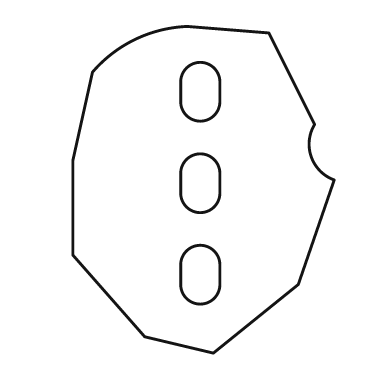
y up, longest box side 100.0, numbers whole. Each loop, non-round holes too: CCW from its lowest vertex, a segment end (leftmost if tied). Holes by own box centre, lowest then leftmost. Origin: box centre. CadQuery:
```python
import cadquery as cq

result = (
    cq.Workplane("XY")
    .moveTo(3.0, -50.0)
    .lineTo(29.0, -29.0)
    .lineTo(40.0, 3.0)
    .threePointArc((33.0, 10.0), (34.0, 20.0))
    .lineTo(20.0, 48.0)
    .lineTo(-5.0, 50.0)
    .threePointArc((-21.0, 46.0), (-34.0, 36.0))
    .lineTo(-40.0, 9.0)
    .lineTo(-40.0, -20.0)
    .lineTo(-18.0, -45.0)
    .close()
    .moveTo(-7.0, -29.0)
    .threePointArc((-1.0, -35.0), (5.0, -29.0))
    .lineTo(5.0, -23.0)
    .threePointArc((-1.0, -17.0), (-7.0, -23.0))
    .close()
    .moveTo(-7.0, -1.0)
    .threePointArc((-1.0, -7.0), (5.0, -1.0))
    .lineTo(5.0, 5.0)
    .threePointArc((-1.0, 11.0), (-7.0, 5.0))
    .close()
    .moveTo(-7.0, 27.0)
    .threePointArc((-1.0, 21.0), (5.0, 27.0))
    .lineTo(5.0, 33.0)
    .threePointArc((-1.0, 39.0), (-7.0, 33.0))
    .close()
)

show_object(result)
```